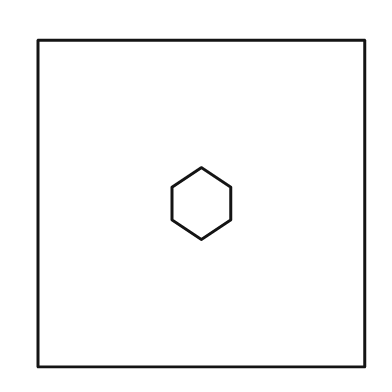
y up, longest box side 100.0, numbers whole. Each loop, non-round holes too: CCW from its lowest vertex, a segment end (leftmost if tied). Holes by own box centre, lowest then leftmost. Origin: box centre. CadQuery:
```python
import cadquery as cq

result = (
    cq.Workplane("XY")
    .moveTo(-50.0, -50.0)
    .lineTo(50.0, -50.0)
    .lineTo(50.0, 50.0)
    .lineTo(-50.0, 50.0)
    .close()
    .moveTo(0.0, -11.0)
    .lineTo(9.0, -5.0)
    .lineTo(9.0, 5.0)
    .lineTo(0.0, 11.0)
    .lineTo(-9.0, 5.0)
    .lineTo(-9.0, -5.0)
    .close()
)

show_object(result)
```